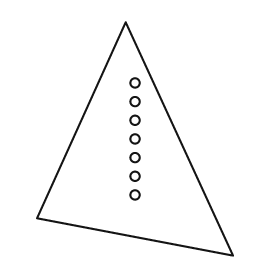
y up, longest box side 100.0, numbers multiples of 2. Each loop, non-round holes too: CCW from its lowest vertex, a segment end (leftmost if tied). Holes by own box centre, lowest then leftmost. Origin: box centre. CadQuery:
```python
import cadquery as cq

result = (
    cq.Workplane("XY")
    .moveTo(42.0, -50.0)
    .lineTo(-4.0, 50.0)
    .lineTo(-42.0, -34.0)
    .close()
    .moveTo(0.0, -24.0)
    .circle(2.0)
    .moveTo(0.0, -16.0)
    .circle(2.0)
    .moveTo(0.0, -8.0)
    .circle(2.0)
    .moveTo(0.0, 0.0)
    .circle(2.0)
    .moveTo(0.0, 8.0)
    .circle(2.0)
    .moveTo(0.0, 16.0)
    .circle(2.0)
    .moveTo(0.0, 24.0)
    .circle(2.0)
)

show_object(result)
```